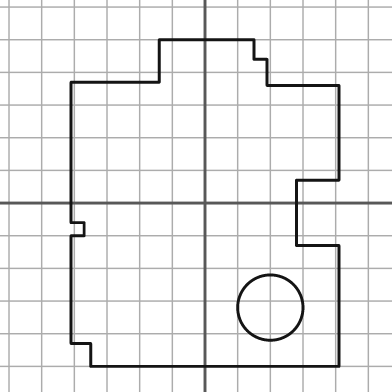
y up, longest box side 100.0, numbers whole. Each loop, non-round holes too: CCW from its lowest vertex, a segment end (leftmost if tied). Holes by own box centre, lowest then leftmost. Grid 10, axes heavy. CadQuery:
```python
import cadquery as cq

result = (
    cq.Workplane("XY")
    .moveTo(-35.0, -50.0)
    .lineTo(41.0, -50.0)
    .lineTo(41.0, -13.0)
    .lineTo(28.0, -13.0)
    .lineTo(28.0, 7.0)
    .lineTo(41.0, 7.0)
    .lineTo(41.0, 36.0)
    .lineTo(19.0, 36.0)
    .lineTo(19.0, 44.0)
    .lineTo(15.0, 44.0)
    .lineTo(15.0, 50.0)
    .lineTo(-14.0, 50.0)
    .lineTo(-14.0, 37.0)
    .lineTo(-41.0, 37.0)
    .lineTo(-41.0, -6.0)
    .lineTo(-37.0, -6.0)
    .lineTo(-37.0, -10.0)
    .lineTo(-41.0, -10.0)
    .lineTo(-41.0, -43.0)
    .lineTo(-35.0, -43.0)
    .close()
    .moveTo(20.0, -32.0)
    .circle(10.0)
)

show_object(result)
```